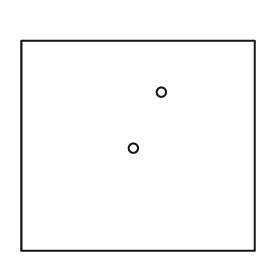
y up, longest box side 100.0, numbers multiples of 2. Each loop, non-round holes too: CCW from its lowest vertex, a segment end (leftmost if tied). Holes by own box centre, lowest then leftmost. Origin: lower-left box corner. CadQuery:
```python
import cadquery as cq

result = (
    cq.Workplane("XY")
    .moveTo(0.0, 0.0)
    .lineTo(100.0, 0.0)
    .lineTo(100.0, 90.0)
    .lineTo(0.0, 90.0)
    .close()
    .moveTo(48.0, 44.0)
    .circle(2.0)
    .moveTo(60.0, 68.0)
    .circle(2.0)
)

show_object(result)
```